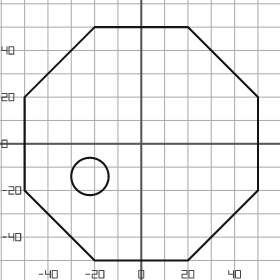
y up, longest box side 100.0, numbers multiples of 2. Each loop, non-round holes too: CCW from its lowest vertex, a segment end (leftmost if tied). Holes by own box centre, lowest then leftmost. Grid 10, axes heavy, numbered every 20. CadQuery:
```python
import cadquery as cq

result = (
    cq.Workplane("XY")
    .moveTo(-20.0, -50.0)
    .lineTo(20.0, -50.0)
    .lineTo(50.0, -20.0)
    .lineTo(50.0, 20.0)
    .lineTo(20.0, 50.0)
    .lineTo(-20.0, 50.0)
    .lineTo(-50.0, 20.0)
    .lineTo(-50.0, -20.0)
    .close()
    .moveTo(-22.0, -14.0)
    .circle(8.0)
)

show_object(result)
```